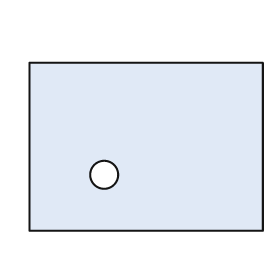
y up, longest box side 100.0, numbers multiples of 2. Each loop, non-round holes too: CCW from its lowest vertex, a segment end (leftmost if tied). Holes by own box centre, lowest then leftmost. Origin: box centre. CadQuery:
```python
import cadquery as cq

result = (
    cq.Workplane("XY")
    .moveTo(-50.0, -36.0)
    .lineTo(50.0, -36.0)
    .lineTo(50.0, 36.0)
    .lineTo(-50.0, 36.0)
    .close()
    .moveTo(-18.0, -12.0)
    .circle(6.0)
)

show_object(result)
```